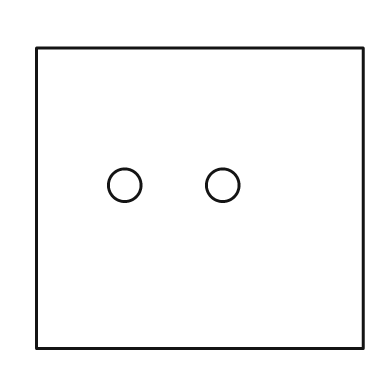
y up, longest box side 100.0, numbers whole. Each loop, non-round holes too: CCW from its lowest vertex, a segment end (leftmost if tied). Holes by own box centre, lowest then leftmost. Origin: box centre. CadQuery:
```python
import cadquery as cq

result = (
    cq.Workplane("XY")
    .moveTo(-50.0, -46.0)
    .lineTo(50.0, -46.0)
    .lineTo(50.0, 46.0)
    .lineTo(-50.0, 46.0)
    .close()
    .moveTo(-23.0, 4.0)
    .circle(5.0)
    .moveTo(7.0, 4.0)
    .circle(5.0)
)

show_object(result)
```